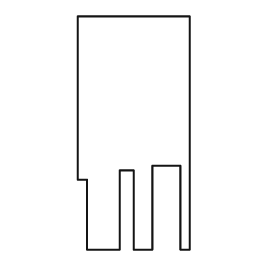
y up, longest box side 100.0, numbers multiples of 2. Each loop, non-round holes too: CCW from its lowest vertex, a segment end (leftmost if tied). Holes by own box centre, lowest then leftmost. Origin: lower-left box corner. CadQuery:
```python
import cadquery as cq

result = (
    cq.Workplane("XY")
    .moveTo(4.0, 0.0)
    .lineTo(18.0, 0.0)
    .lineTo(18.0, 34.0)
    .lineTo(24.0, 34.0)
    .lineTo(24.0, 0.0)
    .lineTo(32.0, 0.0)
    .lineTo(32.0, 36.0)
    .lineTo(44.0, 36.0)
    .lineTo(44.0, 0.0)
    .lineTo(48.0, 0.0)
    .lineTo(48.0, 100.0)
    .lineTo(0.0, 100.0)
    .lineTo(0.0, 30.0)
    .lineTo(4.0, 30.0)
    .close()
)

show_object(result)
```